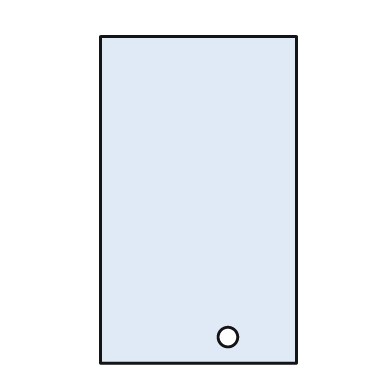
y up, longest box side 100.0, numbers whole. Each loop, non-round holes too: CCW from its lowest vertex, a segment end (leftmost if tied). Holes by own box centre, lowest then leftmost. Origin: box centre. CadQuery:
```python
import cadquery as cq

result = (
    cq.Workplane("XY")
    .moveTo(-30.0, -50.0)
    .lineTo(30.0, -50.0)
    .lineTo(30.0, 50.0)
    .lineTo(-30.0, 50.0)
    .close()
    .moveTo(9.0, -42.0)
    .circle(3.0)
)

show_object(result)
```